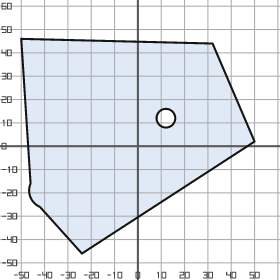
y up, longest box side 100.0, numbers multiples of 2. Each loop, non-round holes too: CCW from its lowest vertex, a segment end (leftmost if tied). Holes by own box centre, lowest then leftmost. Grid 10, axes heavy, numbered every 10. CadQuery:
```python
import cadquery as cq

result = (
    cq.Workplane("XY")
    .moveTo(-24.0, -46.0)
    .lineTo(50.0, 2.0)
    .lineTo(32.0, 44.0)
    .lineTo(-50.0, 46.0)
    .lineTo(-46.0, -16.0)
    .threePointArc((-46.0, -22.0), (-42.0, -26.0))
    .close()
    .moveTo(12.0, 12.0)
    .circle(4.0)
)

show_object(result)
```